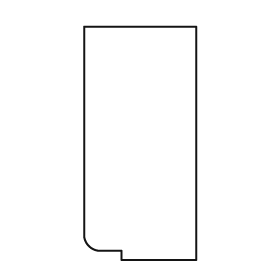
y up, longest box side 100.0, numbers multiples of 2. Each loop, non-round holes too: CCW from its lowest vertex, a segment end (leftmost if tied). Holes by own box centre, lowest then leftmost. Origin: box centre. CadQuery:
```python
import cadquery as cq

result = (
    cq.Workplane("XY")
    .moveTo(-8.0, -50.0)
    .lineTo(24.0, -50.0)
    .lineTo(24.0, 50.0)
    .lineTo(-24.0, 50.0)
    .lineTo(-24.0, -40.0)
    .threePointArc((-22.0, -44.0), (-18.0, -46.0))
    .lineTo(-8.0, -46.0)
    .close()
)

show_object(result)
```